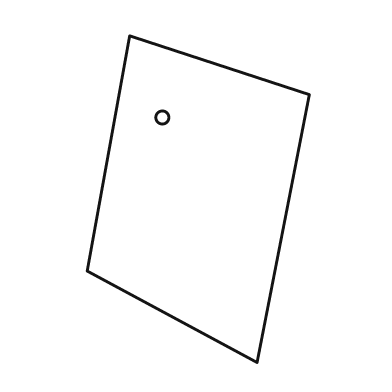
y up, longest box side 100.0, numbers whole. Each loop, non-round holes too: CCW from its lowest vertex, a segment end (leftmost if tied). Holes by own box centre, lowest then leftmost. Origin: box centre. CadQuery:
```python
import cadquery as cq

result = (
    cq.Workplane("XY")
    .moveTo(18.0, -50.0)
    .lineTo(34.0, 32.0)
    .lineTo(-21.0, 50.0)
    .lineTo(-34.0, -22.0)
    .close()
    .moveTo(-11.0, 25.0)
    .circle(2.0)
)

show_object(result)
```